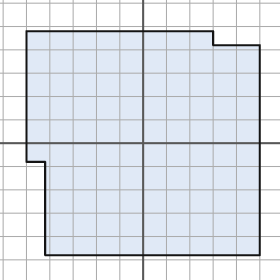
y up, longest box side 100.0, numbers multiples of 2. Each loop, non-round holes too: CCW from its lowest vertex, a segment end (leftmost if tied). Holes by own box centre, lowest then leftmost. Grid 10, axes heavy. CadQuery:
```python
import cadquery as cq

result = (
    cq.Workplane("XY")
    .moveTo(-42.0, -48.0)
    .lineTo(50.0, -48.0)
    .lineTo(50.0, 42.0)
    .lineTo(30.0, 42.0)
    .lineTo(30.0, 48.0)
    .lineTo(-50.0, 48.0)
    .lineTo(-50.0, -8.0)
    .lineTo(-42.0, -8.0)
    .close()
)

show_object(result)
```